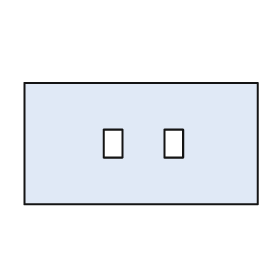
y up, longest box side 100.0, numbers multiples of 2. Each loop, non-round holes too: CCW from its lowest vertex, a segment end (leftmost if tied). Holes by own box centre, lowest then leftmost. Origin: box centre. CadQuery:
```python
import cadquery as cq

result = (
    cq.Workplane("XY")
    .moveTo(-50.0, -26.0)
    .lineTo(50.0, -26.0)
    .lineTo(50.0, 26.0)
    .lineTo(-50.0, 26.0)
    .close()
    .moveTo(-16.0, -6.0)
    .lineTo(-8.0, -6.0)
    .lineTo(-8.0, 6.0)
    .lineTo(-16.0, 6.0)
    .close()
    .moveTo(10.0, -6.0)
    .lineTo(18.0, -6.0)
    .lineTo(18.0, 6.0)
    .lineTo(10.0, 6.0)
    .close()
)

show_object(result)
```